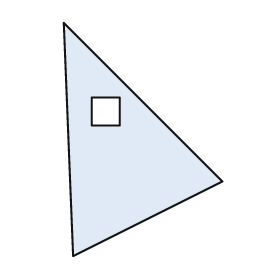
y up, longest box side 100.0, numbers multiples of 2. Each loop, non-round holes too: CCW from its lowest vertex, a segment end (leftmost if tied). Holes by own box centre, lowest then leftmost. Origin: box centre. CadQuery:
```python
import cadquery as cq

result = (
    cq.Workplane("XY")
    .moveTo(-30.0, -50.0)
    .lineTo(34.0, -18.0)
    .lineTo(-34.0, 50.0)
    .close()
    .moveTo(-22.0, 6.0)
    .lineTo(-10.0, 6.0)
    .lineTo(-10.0, 18.0)
    .lineTo(-22.0, 18.0)
    .close()
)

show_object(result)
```